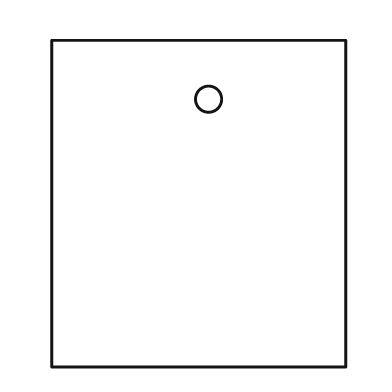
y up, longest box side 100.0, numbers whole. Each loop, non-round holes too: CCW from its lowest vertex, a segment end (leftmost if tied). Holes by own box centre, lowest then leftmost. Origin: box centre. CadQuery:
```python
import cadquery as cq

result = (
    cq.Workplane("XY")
    .moveTo(-45.0, -50.0)
    .lineTo(45.0, -50.0)
    .lineTo(45.0, 50.0)
    .lineTo(-45.0, 50.0)
    .close()
    .moveTo(3.0, 32.0)
    .circle(4.0)
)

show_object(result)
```